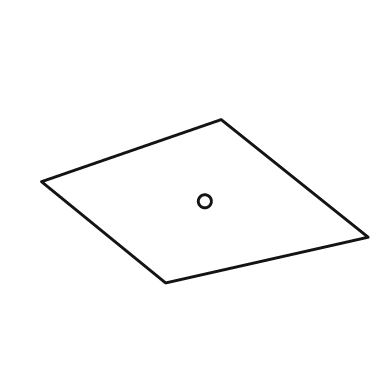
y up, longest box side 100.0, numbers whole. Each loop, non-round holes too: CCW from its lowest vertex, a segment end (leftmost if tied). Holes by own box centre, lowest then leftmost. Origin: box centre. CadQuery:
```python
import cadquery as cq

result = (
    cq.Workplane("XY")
    .moveTo(-12.0, -25.0)
    .lineTo(50.0, -11.0)
    .lineTo(5.0, 25.0)
    .lineTo(-50.0, 6.0)
    .close()
    .moveTo(0.0, 0.0)
    .circle(2.0)
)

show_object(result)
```